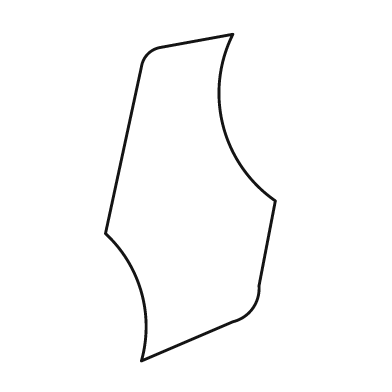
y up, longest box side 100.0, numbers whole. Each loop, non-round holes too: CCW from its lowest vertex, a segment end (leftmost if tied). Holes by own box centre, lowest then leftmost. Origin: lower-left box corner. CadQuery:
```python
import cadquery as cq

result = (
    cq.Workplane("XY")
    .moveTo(11.0, 0.0)
    .lineTo(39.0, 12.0)
    .threePointArc((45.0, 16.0), (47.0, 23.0))
    .lineTo(52.0, 49.0)
    .threePointArc((36.0, 72.0), (39.0, 100.0))
    .lineTo(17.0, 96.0)
    .threePointArc((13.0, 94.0), (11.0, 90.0))
    .lineTo(0.0, 39.0)
    .threePointArc((11.0, 21.0), (11.0, 0.0))
    .close()
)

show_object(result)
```